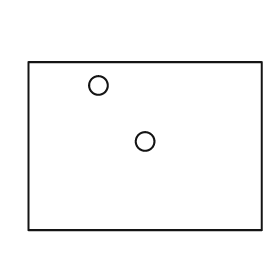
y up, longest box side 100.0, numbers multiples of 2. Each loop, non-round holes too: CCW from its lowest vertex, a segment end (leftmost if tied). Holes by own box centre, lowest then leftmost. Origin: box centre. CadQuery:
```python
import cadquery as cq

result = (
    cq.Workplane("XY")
    .moveTo(-50.0, -36.0)
    .lineTo(50.0, -36.0)
    .lineTo(50.0, 36.0)
    .lineTo(-50.0, 36.0)
    .close()
    .moveTo(0.0, 2.0)
    .circle(4.0)
    .moveTo(-20.0, 26.0)
    .circle(4.0)
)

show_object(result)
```